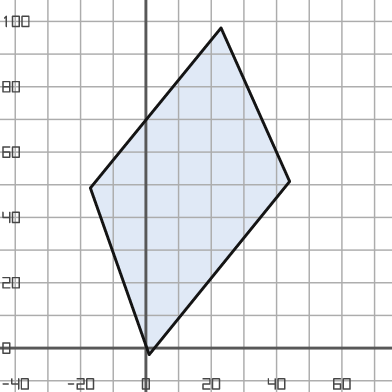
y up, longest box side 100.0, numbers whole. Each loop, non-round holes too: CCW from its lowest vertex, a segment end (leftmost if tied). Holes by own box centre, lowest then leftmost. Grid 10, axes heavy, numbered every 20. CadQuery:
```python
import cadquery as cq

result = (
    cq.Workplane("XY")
    .moveTo(1.0, -2.0)
    .lineTo(44.0, 51.0)
    .lineTo(23.0, 98.0)
    .lineTo(-17.0, 49.0)
    .close()
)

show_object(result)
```